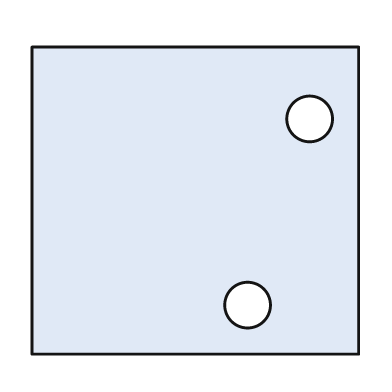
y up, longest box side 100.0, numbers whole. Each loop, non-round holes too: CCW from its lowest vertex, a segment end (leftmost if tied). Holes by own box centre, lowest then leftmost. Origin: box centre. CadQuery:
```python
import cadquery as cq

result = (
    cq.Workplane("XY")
    .moveTo(-50.0, -47.0)
    .lineTo(50.0, -47.0)
    .lineTo(50.0, 47.0)
    .lineTo(-50.0, 47.0)
    .close()
    .moveTo(16.0, -32.0)
    .circle(7.0)
    .moveTo(35.0, 25.0)
    .circle(7.0)
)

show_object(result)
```